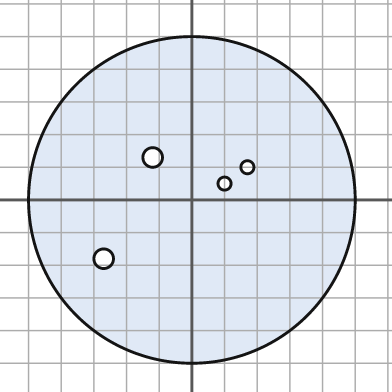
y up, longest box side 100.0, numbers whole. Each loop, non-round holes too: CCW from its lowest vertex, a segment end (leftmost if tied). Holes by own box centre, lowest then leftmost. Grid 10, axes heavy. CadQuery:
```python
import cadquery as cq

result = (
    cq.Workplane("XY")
    .moveTo(0.0, 0.0)
    .circle(50.0)
    .moveTo(-27.0, -18.0)
    .circle(3.0)
    .moveTo(10.0, 5.0)
    .circle(2.0)
    .moveTo(17.0, 10.0)
    .circle(2.0)
    .moveTo(-12.0, 13.0)
    .circle(3.0)
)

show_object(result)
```